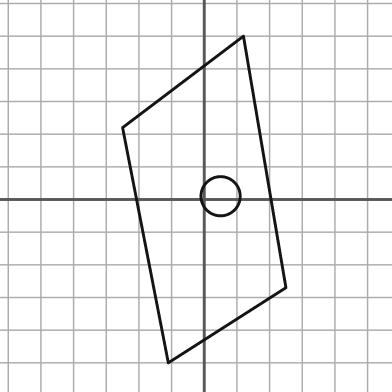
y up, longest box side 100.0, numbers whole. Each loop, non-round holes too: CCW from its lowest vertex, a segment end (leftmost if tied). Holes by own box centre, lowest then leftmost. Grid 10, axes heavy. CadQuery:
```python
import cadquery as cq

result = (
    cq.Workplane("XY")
    .moveTo(-11.0, -50.0)
    .lineTo(25.0, -27.0)
    .lineTo(12.0, 50.0)
    .lineTo(-25.0, 22.0)
    .close()
    .moveTo(5.0, 1.0)
    .circle(6.0)
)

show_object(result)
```